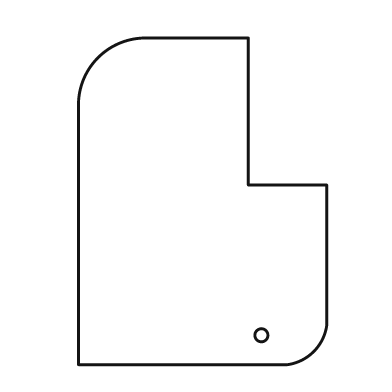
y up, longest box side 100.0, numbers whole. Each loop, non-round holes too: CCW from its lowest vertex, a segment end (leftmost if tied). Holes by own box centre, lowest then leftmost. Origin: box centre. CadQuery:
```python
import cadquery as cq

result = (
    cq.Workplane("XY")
    .moveTo(-38.0, -50.0)
    .lineTo(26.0, -50.0)
    .threePointArc((34.0, -46.0), (38.0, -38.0))
    .lineTo(38.0, 5.0)
    .lineTo(14.0, 5.0)
    .lineTo(14.0, 50.0)
    .lineTo(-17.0, 50.0)
    .threePointArc((-32.0, 44.0), (-38.0, 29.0))
    .close()
    .moveTo(18.0, -41.0)
    .circle(2.0)
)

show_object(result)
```